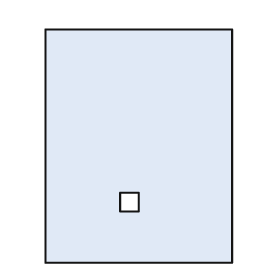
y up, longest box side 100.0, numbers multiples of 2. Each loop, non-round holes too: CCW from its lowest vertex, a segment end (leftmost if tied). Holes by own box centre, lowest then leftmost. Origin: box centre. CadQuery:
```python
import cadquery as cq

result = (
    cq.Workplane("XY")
    .moveTo(-40.0, -50.0)
    .lineTo(40.0, -50.0)
    .lineTo(40.0, 50.0)
    .lineTo(-40.0, 50.0)
    .close()
    .moveTo(-8.0, -28.0)
    .lineTo(0.0, -28.0)
    .lineTo(0.0, -20.0)
    .lineTo(-8.0, -20.0)
    .close()
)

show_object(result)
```